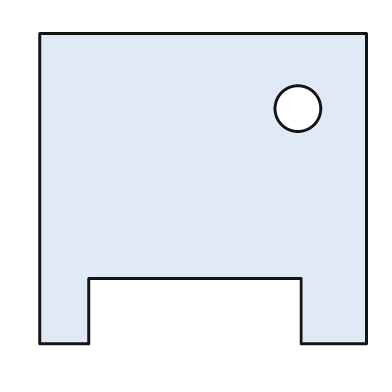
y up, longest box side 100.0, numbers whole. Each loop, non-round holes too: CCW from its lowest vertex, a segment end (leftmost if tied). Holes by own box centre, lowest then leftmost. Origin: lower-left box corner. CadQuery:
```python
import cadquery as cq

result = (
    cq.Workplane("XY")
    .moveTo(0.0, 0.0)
    .lineTo(15.0, 0.0)
    .lineTo(15.0, 20.0)
    .lineTo(80.0, 20.0)
    .lineTo(80.0, 0.0)
    .lineTo(100.0, 0.0)
    .lineTo(100.0, 95.0)
    .lineTo(0.0, 95.0)
    .close()
    .moveTo(79.0, 72.0)
    .circle(7.0)
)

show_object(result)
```